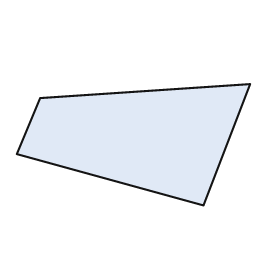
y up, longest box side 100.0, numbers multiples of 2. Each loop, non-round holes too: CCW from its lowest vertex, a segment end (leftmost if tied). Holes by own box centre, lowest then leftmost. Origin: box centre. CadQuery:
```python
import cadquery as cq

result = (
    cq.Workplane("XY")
    .moveTo(30.0, -26.0)
    .lineTo(50.0, 26.0)
    .lineTo(-40.0, 20.0)
    .lineTo(-50.0, -4.0)
    .close()
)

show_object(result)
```